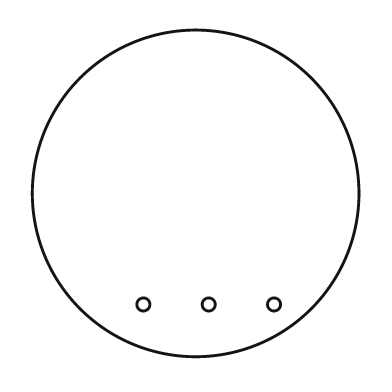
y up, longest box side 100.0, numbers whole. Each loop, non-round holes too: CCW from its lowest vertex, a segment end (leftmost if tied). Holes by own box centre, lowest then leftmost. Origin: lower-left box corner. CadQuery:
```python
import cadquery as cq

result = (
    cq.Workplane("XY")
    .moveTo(50.0, 50.0)
    .circle(50.0)
    .moveTo(34.0, 16.0)
    .circle(2.0)
    .moveTo(54.0, 16.0)
    .circle(2.0)
    .moveTo(74.0, 16.0)
    .circle(2.0)
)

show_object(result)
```